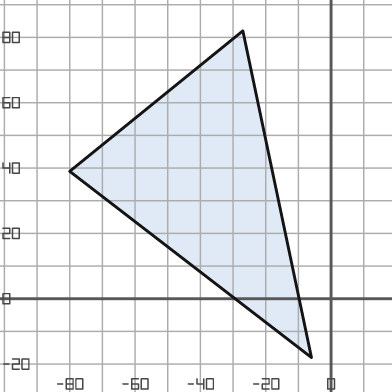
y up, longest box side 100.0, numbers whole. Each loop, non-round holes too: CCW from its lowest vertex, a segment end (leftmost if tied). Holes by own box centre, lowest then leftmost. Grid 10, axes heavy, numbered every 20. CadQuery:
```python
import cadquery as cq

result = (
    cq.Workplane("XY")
    .moveTo(-6.0, -18.0)
    .lineTo(-27.0, 82.0)
    .lineTo(-80.0, 39.0)
    .close()
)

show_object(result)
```